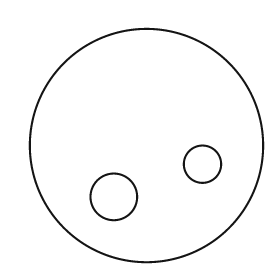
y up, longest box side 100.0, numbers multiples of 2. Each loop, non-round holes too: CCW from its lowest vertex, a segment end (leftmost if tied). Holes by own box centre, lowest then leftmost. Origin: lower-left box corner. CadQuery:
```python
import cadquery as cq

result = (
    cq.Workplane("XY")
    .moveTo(50.0, 50.0)
    .circle(50.0)
    .moveTo(36.0, 28.0)
    .circle(10.0)
    .moveTo(74.0, 42.0)
    .circle(8.0)
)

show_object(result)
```